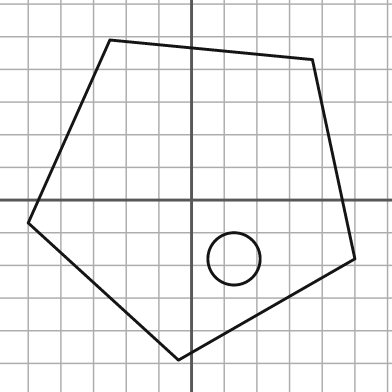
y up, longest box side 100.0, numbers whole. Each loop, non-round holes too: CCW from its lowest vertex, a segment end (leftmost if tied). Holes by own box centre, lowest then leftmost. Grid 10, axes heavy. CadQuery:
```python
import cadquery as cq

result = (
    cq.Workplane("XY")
    .moveTo(-4.0, -49.0)
    .lineTo(50.0, -18.0)
    .lineTo(37.0, 43.0)
    .lineTo(-25.0, 49.0)
    .lineTo(-50.0, -7.0)
    .close()
    .moveTo(13.0, -18.0)
    .circle(8.0)
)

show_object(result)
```